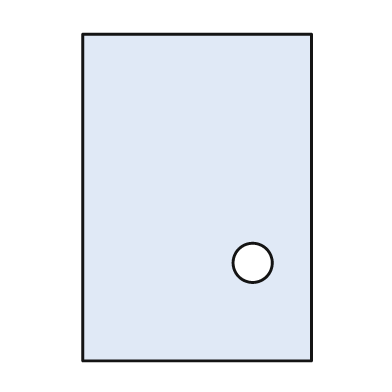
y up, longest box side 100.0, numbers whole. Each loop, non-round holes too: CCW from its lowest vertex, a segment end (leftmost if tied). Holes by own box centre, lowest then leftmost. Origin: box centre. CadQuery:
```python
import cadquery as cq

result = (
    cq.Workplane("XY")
    .moveTo(-35.0, -50.0)
    .lineTo(35.0, -50.0)
    .lineTo(35.0, 50.0)
    .lineTo(-35.0, 50.0)
    .close()
    .moveTo(17.0, -20.0)
    .circle(6.0)
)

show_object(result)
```